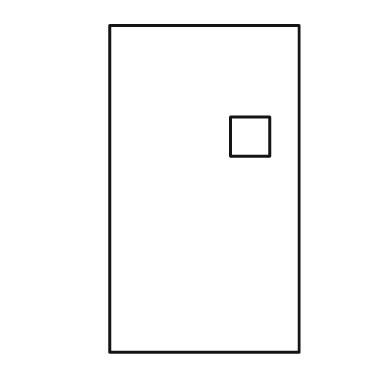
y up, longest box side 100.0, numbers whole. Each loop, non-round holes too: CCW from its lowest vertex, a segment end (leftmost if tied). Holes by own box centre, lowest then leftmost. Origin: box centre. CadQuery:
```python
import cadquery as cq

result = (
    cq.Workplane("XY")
    .moveTo(-29.0, -50.0)
    .lineTo(29.0, -50.0)
    .lineTo(29.0, 50.0)
    .lineTo(-29.0, 50.0)
    .close()
    .moveTo(8.0, 10.0)
    .lineTo(20.0, 10.0)
    .lineTo(20.0, 22.0)
    .lineTo(8.0, 22.0)
    .close()
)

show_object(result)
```